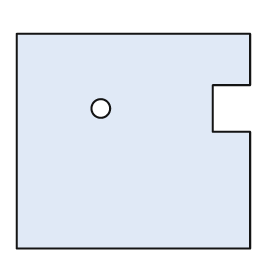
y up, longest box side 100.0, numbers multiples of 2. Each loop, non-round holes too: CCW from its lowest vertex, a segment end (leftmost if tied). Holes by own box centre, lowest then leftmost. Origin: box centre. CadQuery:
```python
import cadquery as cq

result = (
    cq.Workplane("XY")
    .moveTo(-50.0, -46.0)
    .lineTo(50.0, -46.0)
    .lineTo(50.0, 4.0)
    .lineTo(34.0, 4.0)
    .lineTo(34.0, 24.0)
    .lineTo(50.0, 24.0)
    .lineTo(50.0, 46.0)
    .lineTo(-50.0, 46.0)
    .close()
    .moveTo(-14.0, 14.0)
    .circle(4.0)
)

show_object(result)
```